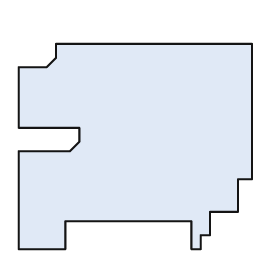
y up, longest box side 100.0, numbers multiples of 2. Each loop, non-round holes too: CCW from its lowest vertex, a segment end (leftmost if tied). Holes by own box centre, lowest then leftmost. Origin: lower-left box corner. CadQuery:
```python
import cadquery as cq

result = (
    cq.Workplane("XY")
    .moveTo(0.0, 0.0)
    .lineTo(20.0, 0.0)
    .lineTo(20.0, 12.0)
    .lineTo(74.0, 12.0)
    .lineTo(74.0, 0.0)
    .lineTo(78.0, 0.0)
    .lineTo(78.0, 6.0)
    .lineTo(82.0, 6.0)
    .lineTo(82.0, 16.0)
    .lineTo(94.0, 16.0)
    .lineTo(94.0, 30.0)
    .lineTo(100.0, 30.0)
    .lineTo(100.0, 88.0)
    .lineTo(16.0, 88.0)
    .lineTo(16.0, 82.0)
    .lineTo(12.0, 78.0)
    .lineTo(0.0, 78.0)
    .lineTo(0.0, 52.0)
    .lineTo(26.0, 52.0)
    .lineTo(26.0, 46.0)
    .lineTo(22.0, 42.0)
    .lineTo(0.0, 42.0)
    .close()
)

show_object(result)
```